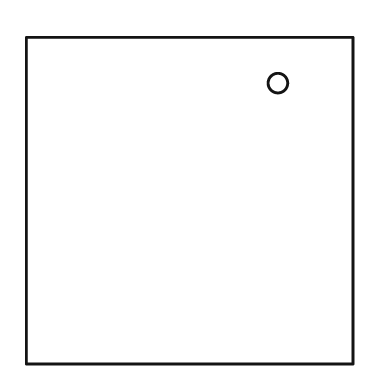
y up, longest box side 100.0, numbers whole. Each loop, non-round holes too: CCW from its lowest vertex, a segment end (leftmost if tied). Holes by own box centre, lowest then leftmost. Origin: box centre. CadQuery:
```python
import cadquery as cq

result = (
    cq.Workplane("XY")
    .moveTo(-50.0, -50.0)
    .lineTo(50.0, -50.0)
    .lineTo(50.0, 50.0)
    .lineTo(-50.0, 50.0)
    .close()
    .moveTo(27.0, 36.0)
    .circle(3.0)
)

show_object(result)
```